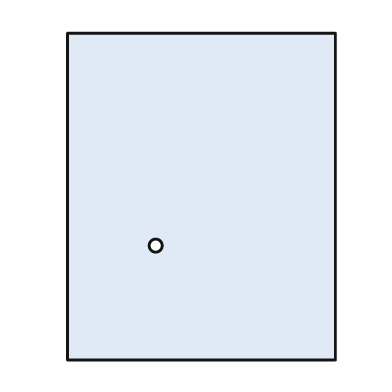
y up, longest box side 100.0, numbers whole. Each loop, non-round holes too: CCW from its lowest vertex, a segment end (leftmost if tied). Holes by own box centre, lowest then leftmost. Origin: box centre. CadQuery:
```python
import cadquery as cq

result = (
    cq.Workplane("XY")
    .moveTo(-41.0, -50.0)
    .lineTo(41.0, -50.0)
    .lineTo(41.0, 50.0)
    .lineTo(-41.0, 50.0)
    .close()
    .moveTo(-14.0, -15.0)
    .circle(2.0)
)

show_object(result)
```